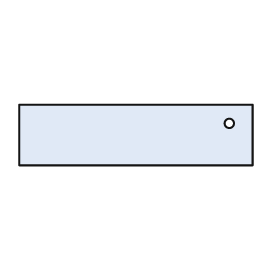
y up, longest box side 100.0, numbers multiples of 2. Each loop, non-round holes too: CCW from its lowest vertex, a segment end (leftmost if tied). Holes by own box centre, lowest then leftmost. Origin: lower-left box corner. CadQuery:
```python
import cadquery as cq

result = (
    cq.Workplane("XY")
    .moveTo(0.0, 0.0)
    .lineTo(100.0, 0.0)
    .lineTo(100.0, 26.0)
    .lineTo(0.0, 26.0)
    .close()
    .moveTo(90.0, 18.0)
    .circle(2.0)
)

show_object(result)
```